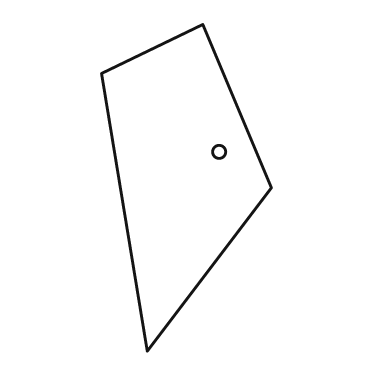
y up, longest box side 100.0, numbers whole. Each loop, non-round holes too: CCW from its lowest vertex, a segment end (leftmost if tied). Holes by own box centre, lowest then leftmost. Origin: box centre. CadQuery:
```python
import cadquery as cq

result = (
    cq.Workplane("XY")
    .moveTo(-12.0, -50.0)
    .lineTo(26.0, 0.0)
    .lineTo(5.0, 50.0)
    .lineTo(-26.0, 35.0)
    .close()
    .moveTo(10.0, 11.0)
    .circle(2.0)
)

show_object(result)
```